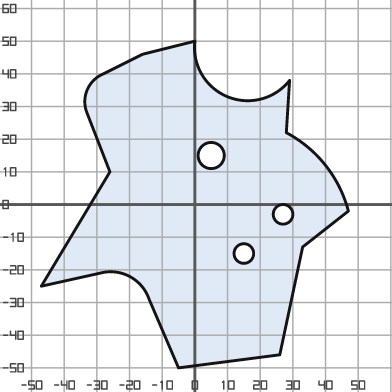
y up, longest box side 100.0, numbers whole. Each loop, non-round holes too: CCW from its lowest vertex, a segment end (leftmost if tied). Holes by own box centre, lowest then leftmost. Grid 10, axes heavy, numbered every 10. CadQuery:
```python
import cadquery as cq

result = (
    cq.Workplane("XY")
    .moveTo(-5.0, -50.0)
    .lineTo(26.0, -46.0)
    .lineTo(33.0, -13.0)
    .lineTo(47.0, -2.0)
    .threePointArc((40.0, 12.0), (28.0, 22.0))
    .lineTo(29.0, 38.0)
    .threePointArc((10.0, 33.0), (0.0, 50.0))
    .lineTo(-16.0, 46.0)
    .lineTo(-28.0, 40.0)
    .threePointArc((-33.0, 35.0), (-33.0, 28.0))
    .lineTo(-26.0, 10.0)
    .lineTo(-47.0, -25.0)
    .lineTo(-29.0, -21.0)
    .threePointArc((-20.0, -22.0), (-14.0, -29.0))
    .close()
    .moveTo(15.0, -15.0)
    .circle(3.0)
    .moveTo(27.0, -3.0)
    .circle(3.0)
    .moveTo(5.0, 15.0)
    .circle(4.0)
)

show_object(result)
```